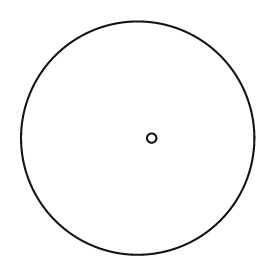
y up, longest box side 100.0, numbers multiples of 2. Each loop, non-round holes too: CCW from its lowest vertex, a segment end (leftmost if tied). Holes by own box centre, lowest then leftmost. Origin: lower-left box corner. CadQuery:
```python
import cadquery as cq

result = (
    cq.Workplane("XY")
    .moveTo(50.0, 50.0)
    .circle(50.0)
    .moveTo(56.0, 50.0)
    .circle(2.0)
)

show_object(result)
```